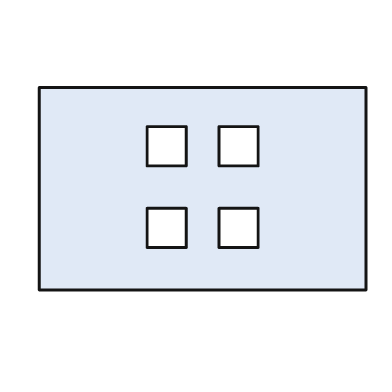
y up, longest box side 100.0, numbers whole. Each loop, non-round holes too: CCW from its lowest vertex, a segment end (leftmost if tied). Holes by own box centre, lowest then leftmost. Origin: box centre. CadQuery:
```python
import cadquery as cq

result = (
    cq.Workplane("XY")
    .moveTo(-50.0, -31.0)
    .lineTo(50.0, -31.0)
    .lineTo(50.0, 31.0)
    .lineTo(-50.0, 31.0)
    .close()
    .moveTo(-17.0, -18.0)
    .lineTo(-5.0, -18.0)
    .lineTo(-5.0, -6.0)
    .lineTo(-17.0, -6.0)
    .close()
    .moveTo(5.0, -18.0)
    .lineTo(17.0, -18.0)
    .lineTo(17.0, -6.0)
    .lineTo(5.0, -6.0)
    .close()
    .moveTo(-17.0, 7.0)
    .lineTo(-5.0, 7.0)
    .lineTo(-5.0, 19.0)
    .lineTo(-17.0, 19.0)
    .close()
    .moveTo(5.0, 7.0)
    .lineTo(17.0, 7.0)
    .lineTo(17.0, 19.0)
    .lineTo(5.0, 19.0)
    .close()
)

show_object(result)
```